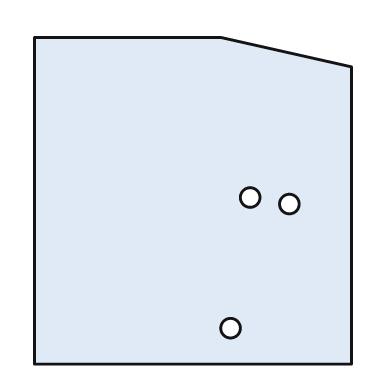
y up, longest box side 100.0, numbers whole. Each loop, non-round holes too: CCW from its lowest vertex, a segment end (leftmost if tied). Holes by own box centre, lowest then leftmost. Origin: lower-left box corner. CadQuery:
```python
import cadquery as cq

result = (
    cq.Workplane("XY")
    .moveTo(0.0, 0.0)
    .lineTo(97.0, 0.0)
    .lineTo(97.0, 91.0)
    .lineTo(57.0, 100.0)
    .lineTo(0.0, 100.0)
    .close()
    .moveTo(60.0, 11.0)
    .circle(3.0)
    .moveTo(78.0, 49.0)
    .circle(3.0)
    .moveTo(66.0, 51.0)
    .circle(3.0)
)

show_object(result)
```